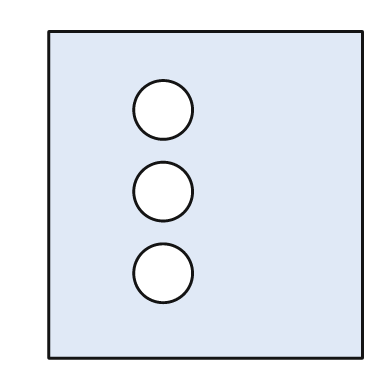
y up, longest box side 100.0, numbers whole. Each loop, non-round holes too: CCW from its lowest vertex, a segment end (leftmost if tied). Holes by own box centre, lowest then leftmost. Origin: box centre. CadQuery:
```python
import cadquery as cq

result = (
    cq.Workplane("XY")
    .moveTo(-48.0, -50.0)
    .lineTo(48.0, -50.0)
    .lineTo(48.0, 50.0)
    .lineTo(-48.0, 50.0)
    .close()
    .moveTo(-13.0, -24.0)
    .circle(9.0)
    .moveTo(-13.0, 1.0)
    .circle(9.0)
    .moveTo(-13.0, 26.0)
    .circle(9.0)
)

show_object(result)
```